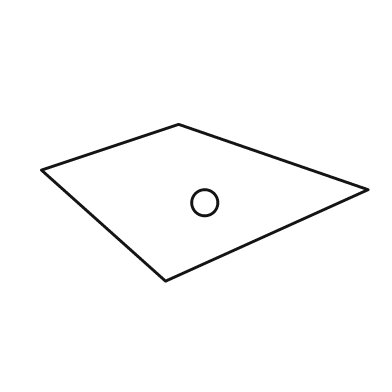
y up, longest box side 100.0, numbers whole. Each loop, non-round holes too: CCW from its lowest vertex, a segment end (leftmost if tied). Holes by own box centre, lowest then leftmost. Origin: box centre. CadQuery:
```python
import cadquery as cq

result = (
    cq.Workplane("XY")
    .moveTo(-12.0, -24.0)
    .lineTo(50.0, 4.0)
    .lineTo(-8.0, 24.0)
    .lineTo(-50.0, 10.0)
    .close()
    .moveTo(0.0, 0.0)
    .circle(4.0)
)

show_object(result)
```